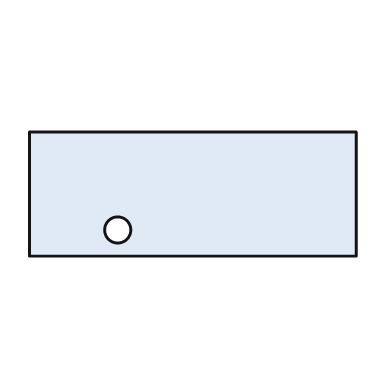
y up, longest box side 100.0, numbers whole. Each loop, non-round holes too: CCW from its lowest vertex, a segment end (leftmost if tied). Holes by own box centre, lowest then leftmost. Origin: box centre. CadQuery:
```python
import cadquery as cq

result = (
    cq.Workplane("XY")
    .moveTo(-50.0, -19.0)
    .lineTo(50.0, -19.0)
    .lineTo(50.0, 19.0)
    .lineTo(-50.0, 19.0)
    .close()
    .moveTo(-23.0, -11.0)
    .circle(4.0)
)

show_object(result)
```